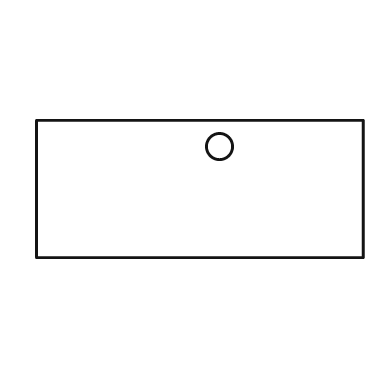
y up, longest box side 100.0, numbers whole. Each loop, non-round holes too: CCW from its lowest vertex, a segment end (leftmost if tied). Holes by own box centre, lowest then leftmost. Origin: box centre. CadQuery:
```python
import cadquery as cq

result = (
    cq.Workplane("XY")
    .moveTo(-50.0, -21.0)
    .lineTo(50.0, -21.0)
    .lineTo(50.0, 21.0)
    .lineTo(-50.0, 21.0)
    .close()
    .moveTo(6.0, 13.0)
    .circle(4.0)
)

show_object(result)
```